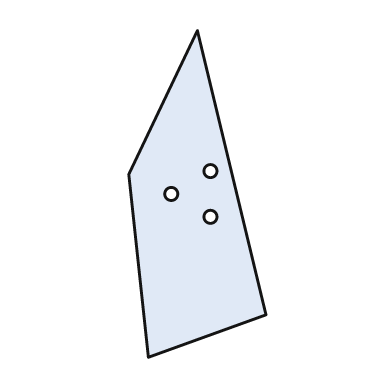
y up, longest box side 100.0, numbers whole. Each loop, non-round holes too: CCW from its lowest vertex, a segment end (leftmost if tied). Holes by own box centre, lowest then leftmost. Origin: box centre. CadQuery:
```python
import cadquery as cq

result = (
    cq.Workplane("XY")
    .moveTo(-15.0, -50.0)
    .lineTo(21.0, -37.0)
    .lineTo(0.0, 50.0)
    .lineTo(-21.0, 6.0)
    .close()
    .moveTo(4.0, -7.0)
    .circle(2.0)
    .moveTo(-8.0, 0.0)
    .circle(2.0)
    .moveTo(4.0, 7.0)
    .circle(2.0)
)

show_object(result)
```